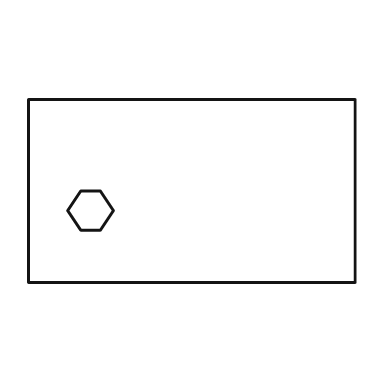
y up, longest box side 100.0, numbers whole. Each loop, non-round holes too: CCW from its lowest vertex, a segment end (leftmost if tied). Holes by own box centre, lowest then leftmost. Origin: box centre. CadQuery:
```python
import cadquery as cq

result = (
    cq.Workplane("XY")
    .moveTo(-50.0, -28.0)
    .lineTo(50.0, -28.0)
    .lineTo(50.0, 28.0)
    .lineTo(-50.0, 28.0)
    .close()
    .moveTo(-34.0, -12.0)
    .lineTo(-28.0, -12.0)
    .lineTo(-24.0, -6.0)
    .lineTo(-28.0, 0.0)
    .lineTo(-34.0, 0.0)
    .lineTo(-38.0, -6.0)
    .close()
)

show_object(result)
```